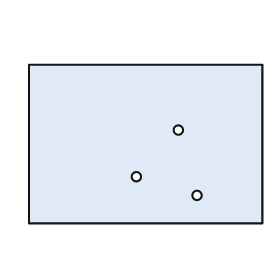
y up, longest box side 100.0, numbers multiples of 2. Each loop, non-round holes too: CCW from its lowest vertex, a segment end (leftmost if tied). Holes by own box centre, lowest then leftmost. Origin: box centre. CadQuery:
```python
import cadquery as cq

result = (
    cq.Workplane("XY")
    .moveTo(-50.0, -34.0)
    .lineTo(50.0, -34.0)
    .lineTo(50.0, 34.0)
    .lineTo(-50.0, 34.0)
    .close()
    .moveTo(22.0, -22.0)
    .circle(2.0)
    .moveTo(-4.0, -14.0)
    .circle(2.0)
    .moveTo(14.0, 6.0)
    .circle(2.0)
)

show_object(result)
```